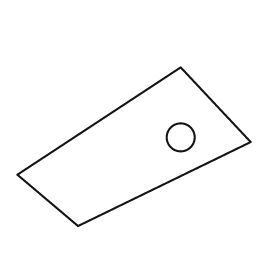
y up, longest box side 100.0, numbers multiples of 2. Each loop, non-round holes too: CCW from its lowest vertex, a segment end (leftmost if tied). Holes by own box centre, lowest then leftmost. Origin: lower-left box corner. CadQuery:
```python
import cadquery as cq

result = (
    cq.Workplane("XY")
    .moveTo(26.0, 0.0)
    .lineTo(100.0, 36.0)
    .lineTo(70.0, 68.0)
    .lineTo(0.0, 22.0)
    .close()
    .moveTo(70.0, 38.0)
    .circle(6.0)
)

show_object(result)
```